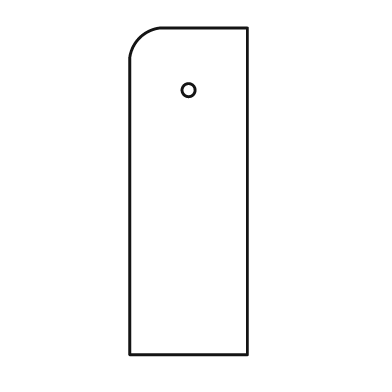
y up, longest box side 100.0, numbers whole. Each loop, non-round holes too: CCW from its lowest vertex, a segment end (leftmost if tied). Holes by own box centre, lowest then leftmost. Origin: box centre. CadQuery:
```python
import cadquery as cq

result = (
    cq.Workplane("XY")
    .moveTo(-18.0, -50.0)
    .lineTo(18.0, -50.0)
    .lineTo(18.0, 50.0)
    .lineTo(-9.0, 50.0)
    .threePointArc((-15.0, 47.0), (-18.0, 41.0))
    .close()
    .moveTo(0.0, 31.0)
    .circle(2.0)
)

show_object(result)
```